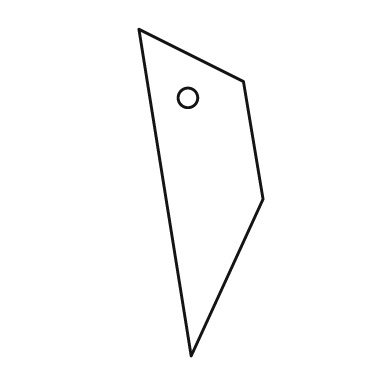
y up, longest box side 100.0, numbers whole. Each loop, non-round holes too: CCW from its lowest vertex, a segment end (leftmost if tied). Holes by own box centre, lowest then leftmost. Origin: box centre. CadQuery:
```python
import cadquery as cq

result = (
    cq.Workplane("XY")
    .moveTo(-3.0, -50.0)
    .lineTo(19.0, -2.0)
    .lineTo(13.0, 34.0)
    .lineTo(-19.0, 50.0)
    .close()
    .moveTo(-4.0, 29.0)
    .circle(3.0)
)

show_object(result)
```